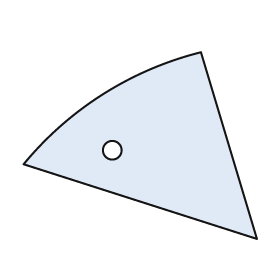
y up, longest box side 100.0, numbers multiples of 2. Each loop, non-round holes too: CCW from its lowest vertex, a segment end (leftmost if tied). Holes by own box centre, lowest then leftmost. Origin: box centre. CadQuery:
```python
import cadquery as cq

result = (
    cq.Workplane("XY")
    .moveTo(50.0, -40.0)
    .lineTo(26.0, 40.0)
    .threePointArc((-16.0, 22.0), (-50.0, -8.0))
    .close()
    .moveTo(-12.0, -2.0)
    .circle(4.0)
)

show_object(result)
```